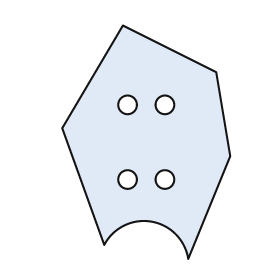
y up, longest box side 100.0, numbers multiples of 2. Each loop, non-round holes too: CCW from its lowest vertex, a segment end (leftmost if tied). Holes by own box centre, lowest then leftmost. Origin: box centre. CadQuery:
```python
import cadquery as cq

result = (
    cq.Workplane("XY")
    .moveTo(18.0, -50.0)
    .lineTo(36.0, -6.0)
    .lineTo(30.0, 30.0)
    .lineTo(-10.0, 50.0)
    .lineTo(-36.0, 6.0)
    .lineTo(-18.0, -44.0)
    .threePointArc((2.0, -34.0), (18.0, -50.0))
    .close()
    .moveTo(-8.0, -16.0)
    .circle(4.0)
    .moveTo(8.0, -16.0)
    .circle(4.0)
    .moveTo(-8.0, 16.0)
    .circle(4.0)
    .moveTo(8.0, 16.0)
    .circle(4.0)
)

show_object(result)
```